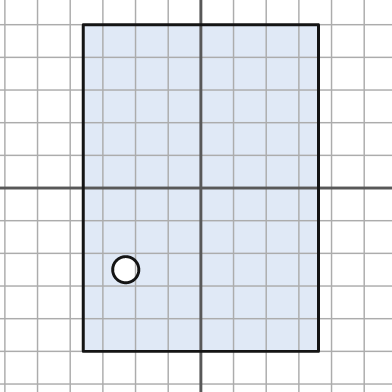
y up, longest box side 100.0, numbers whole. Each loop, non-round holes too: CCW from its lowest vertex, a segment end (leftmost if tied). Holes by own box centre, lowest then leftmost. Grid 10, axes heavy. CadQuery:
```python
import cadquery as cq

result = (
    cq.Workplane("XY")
    .moveTo(-36.0, -50.0)
    .lineTo(36.0, -50.0)
    .lineTo(36.0, 50.0)
    .lineTo(-36.0, 50.0)
    .close()
    .moveTo(-23.0, -25.0)
    .circle(4.0)
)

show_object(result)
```